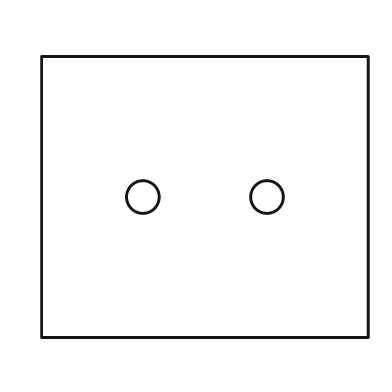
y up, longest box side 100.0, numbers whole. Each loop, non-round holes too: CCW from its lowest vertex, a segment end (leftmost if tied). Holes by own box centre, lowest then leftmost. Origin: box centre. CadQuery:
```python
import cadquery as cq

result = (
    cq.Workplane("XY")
    .moveTo(-50.0, -43.0)
    .lineTo(50.0, -43.0)
    .lineTo(50.0, 43.0)
    .lineTo(-50.0, 43.0)
    .close()
    .moveTo(-19.0, 0.0)
    .circle(5.0)
    .moveTo(19.0, 0.0)
    .circle(5.0)
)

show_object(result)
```